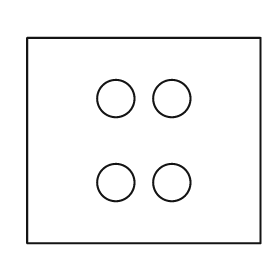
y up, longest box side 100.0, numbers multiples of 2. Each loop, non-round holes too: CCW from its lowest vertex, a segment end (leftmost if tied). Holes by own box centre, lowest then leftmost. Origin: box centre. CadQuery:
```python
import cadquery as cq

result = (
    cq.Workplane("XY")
    .moveTo(-50.0, -44.0)
    .lineTo(50.0, -44.0)
    .lineTo(50.0, 44.0)
    .lineTo(-50.0, 44.0)
    .close()
    .moveTo(-12.0, -18.0)
    .circle(8.0)
    .moveTo(12.0, -18.0)
    .circle(8.0)
    .moveTo(-12.0, 18.0)
    .circle(8.0)
    .moveTo(12.0, 18.0)
    .circle(8.0)
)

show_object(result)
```